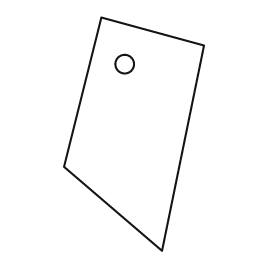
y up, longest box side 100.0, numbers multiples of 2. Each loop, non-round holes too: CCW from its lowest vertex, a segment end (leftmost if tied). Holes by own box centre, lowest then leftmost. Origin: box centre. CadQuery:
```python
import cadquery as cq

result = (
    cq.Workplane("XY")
    .moveTo(12.0, -50.0)
    .lineTo(30.0, 38.0)
    .lineTo(-14.0, 50.0)
    .lineTo(-30.0, -14.0)
    .close()
    .moveTo(-4.0, 30.0)
    .circle(4.0)
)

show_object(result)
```